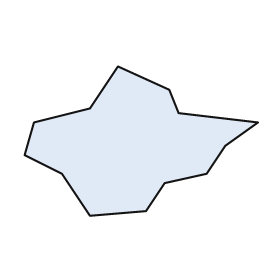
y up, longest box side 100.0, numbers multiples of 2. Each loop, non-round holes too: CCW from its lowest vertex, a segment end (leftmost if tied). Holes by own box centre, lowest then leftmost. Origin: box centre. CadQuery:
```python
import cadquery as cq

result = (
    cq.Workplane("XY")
    .moveTo(-22.0, -32.0)
    .lineTo(2.0, -30.0)
    .lineTo(10.0, -18.0)
    .lineTo(28.0, -14.0)
    .lineTo(36.0, -2.0)
    .lineTo(50.0, 8.0)
    .lineTo(16.0, 12.0)
    .lineTo(12.0, 22.0)
    .lineTo(-10.0, 32.0)
    .lineTo(-22.0, 14.0)
    .lineTo(-46.0, 8.0)
    .lineTo(-50.0, -6.0)
    .lineTo(-34.0, -14.0)
    .close()
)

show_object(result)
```